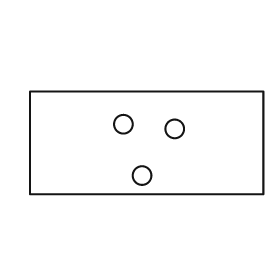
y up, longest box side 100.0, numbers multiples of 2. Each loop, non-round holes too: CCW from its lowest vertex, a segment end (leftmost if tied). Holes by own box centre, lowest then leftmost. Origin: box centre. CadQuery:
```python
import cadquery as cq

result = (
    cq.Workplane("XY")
    .moveTo(-50.0, -22.0)
    .lineTo(50.0, -22.0)
    .lineTo(50.0, 22.0)
    .lineTo(-50.0, 22.0)
    .close()
    .moveTo(-2.0, -14.0)
    .circle(4.0)
    .moveTo(12.0, 6.0)
    .circle(4.0)
    .moveTo(-10.0, 8.0)
    .circle(4.0)
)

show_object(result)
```